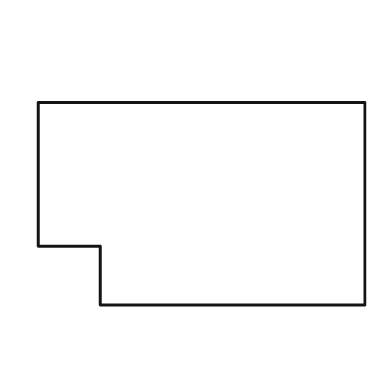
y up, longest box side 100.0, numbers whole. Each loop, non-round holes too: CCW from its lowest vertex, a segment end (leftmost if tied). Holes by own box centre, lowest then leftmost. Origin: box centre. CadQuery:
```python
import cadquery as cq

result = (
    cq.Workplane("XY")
    .moveTo(-31.0, -31.0)
    .lineTo(50.0, -31.0)
    .lineTo(50.0, 31.0)
    .lineTo(-50.0, 31.0)
    .lineTo(-50.0, -13.0)
    .lineTo(-31.0, -13.0)
    .close()
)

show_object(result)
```